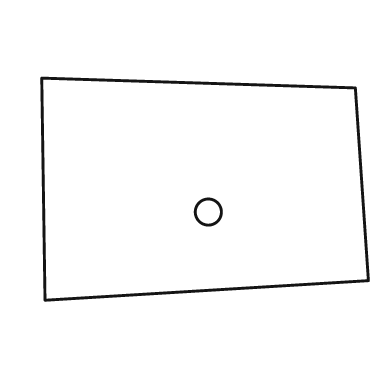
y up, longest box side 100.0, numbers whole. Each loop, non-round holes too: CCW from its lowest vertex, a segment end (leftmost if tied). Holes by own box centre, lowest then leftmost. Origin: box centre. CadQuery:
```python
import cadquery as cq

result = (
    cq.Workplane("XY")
    .moveTo(-49.0, -34.0)
    .lineTo(50.0, -28.0)
    .lineTo(46.0, 31.0)
    .lineTo(-50.0, 34.0)
    .close()
    .moveTo(1.0, -7.0)
    .circle(4.0)
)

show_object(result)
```